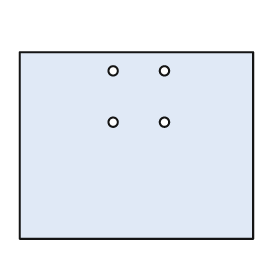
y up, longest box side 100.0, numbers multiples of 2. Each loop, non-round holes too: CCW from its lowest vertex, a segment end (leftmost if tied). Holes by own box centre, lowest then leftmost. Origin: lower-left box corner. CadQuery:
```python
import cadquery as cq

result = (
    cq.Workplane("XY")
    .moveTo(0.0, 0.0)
    .lineTo(100.0, 0.0)
    .lineTo(100.0, 80.0)
    .lineTo(0.0, 80.0)
    .close()
    .moveTo(40.0, 50.0)
    .circle(2.0)
    .moveTo(62.0, 50.0)
    .circle(2.0)
    .moveTo(40.0, 72.0)
    .circle(2.0)
    .moveTo(62.0, 72.0)
    .circle(2.0)
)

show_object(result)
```